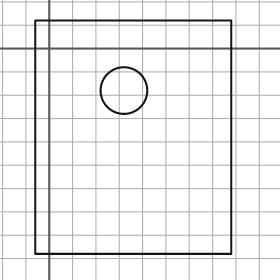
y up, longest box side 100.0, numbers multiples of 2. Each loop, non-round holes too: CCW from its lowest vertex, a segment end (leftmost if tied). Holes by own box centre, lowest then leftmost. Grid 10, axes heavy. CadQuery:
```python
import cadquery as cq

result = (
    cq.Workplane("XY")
    .moveTo(-6.0, -88.0)
    .lineTo(78.0, -88.0)
    .lineTo(78.0, 12.0)
    .lineTo(-6.0, 12.0)
    .close()
    .moveTo(32.0, -18.0)
    .circle(10.0)
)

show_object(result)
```